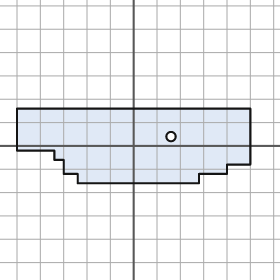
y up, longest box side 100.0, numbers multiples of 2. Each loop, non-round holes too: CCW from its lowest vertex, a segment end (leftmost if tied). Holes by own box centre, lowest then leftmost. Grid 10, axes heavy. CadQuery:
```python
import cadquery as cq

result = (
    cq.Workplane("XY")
    .moveTo(-24.0, -16.0)
    .lineTo(28.0, -16.0)
    .lineTo(28.0, -12.0)
    .lineTo(40.0, -12.0)
    .lineTo(40.0, -8.0)
    .lineTo(50.0, -8.0)
    .lineTo(50.0, 16.0)
    .lineTo(-50.0, 16.0)
    .lineTo(-50.0, -2.0)
    .lineTo(-34.0, -2.0)
    .lineTo(-34.0, -6.0)
    .lineTo(-30.0, -6.0)
    .lineTo(-30.0, -12.0)
    .lineTo(-24.0, -12.0)
    .close()
    .moveTo(16.0, 4.0)
    .circle(2.0)
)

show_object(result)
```